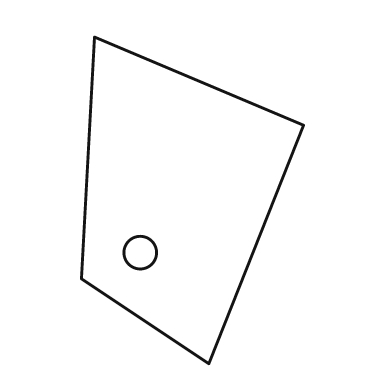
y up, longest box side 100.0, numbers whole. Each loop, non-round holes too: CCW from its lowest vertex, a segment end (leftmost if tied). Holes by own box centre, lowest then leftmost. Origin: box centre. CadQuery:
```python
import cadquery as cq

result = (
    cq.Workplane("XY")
    .moveTo(5.0, -50.0)
    .lineTo(34.0, 23.0)
    .lineTo(-30.0, 50.0)
    .lineTo(-34.0, -24.0)
    .close()
    .moveTo(-16.0, -16.0)
    .circle(5.0)
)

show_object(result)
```